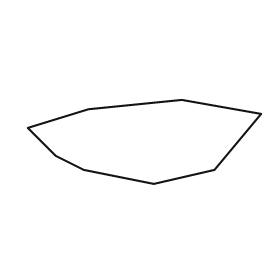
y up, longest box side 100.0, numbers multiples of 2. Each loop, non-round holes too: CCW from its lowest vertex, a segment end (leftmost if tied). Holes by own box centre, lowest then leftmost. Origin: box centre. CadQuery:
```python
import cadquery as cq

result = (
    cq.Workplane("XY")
    .moveTo(4.0, -18.0)
    .lineTo(30.0, -12.0)
    .lineTo(50.0, 12.0)
    .lineTo(16.0, 18.0)
    .lineTo(-24.0, 14.0)
    .lineTo(-50.0, 6.0)
    .lineTo(-38.0, -6.0)
    .lineTo(-26.0, -12.0)
    .close()
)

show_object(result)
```